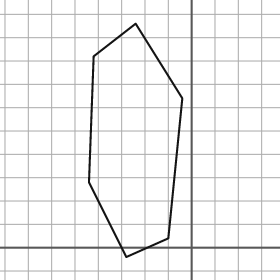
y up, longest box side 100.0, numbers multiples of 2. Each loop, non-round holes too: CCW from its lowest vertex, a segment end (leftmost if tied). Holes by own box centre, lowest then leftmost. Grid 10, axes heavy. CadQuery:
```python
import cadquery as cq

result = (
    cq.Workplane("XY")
    .moveTo(-28.0, -4.0)
    .lineTo(-10.0, 4.0)
    .lineTo(-4.0, 64.0)
    .lineTo(-24.0, 96.0)
    .lineTo(-42.0, 82.0)
    .lineTo(-44.0, 28.0)
    .close()
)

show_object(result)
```